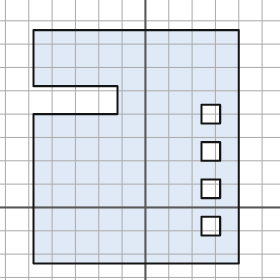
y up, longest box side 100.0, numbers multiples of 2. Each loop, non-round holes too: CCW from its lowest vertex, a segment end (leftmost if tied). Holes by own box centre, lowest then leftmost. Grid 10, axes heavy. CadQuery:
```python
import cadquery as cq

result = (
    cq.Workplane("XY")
    .moveTo(-48.0, -24.0)
    .lineTo(40.0, -24.0)
    .lineTo(40.0, 76.0)
    .lineTo(-48.0, 76.0)
    .lineTo(-48.0, 52.0)
    .lineTo(-12.0, 52.0)
    .lineTo(-12.0, 40.0)
    .lineTo(-48.0, 40.0)
    .close()
    .moveTo(24.0, -12.0)
    .lineTo(32.0, -12.0)
    .lineTo(32.0, -4.0)
    .lineTo(24.0, -4.0)
    .close()
    .moveTo(24.0, 4.0)
    .lineTo(32.0, 4.0)
    .lineTo(32.0, 12.0)
    .lineTo(24.0, 12.0)
    .close()
    .moveTo(24.0, 20.0)
    .lineTo(32.0, 20.0)
    .lineTo(32.0, 28.0)
    .lineTo(24.0, 28.0)
    .close()
    .moveTo(24.0, 36.0)
    .lineTo(32.0, 36.0)
    .lineTo(32.0, 44.0)
    .lineTo(24.0, 44.0)
    .close()
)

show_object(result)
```